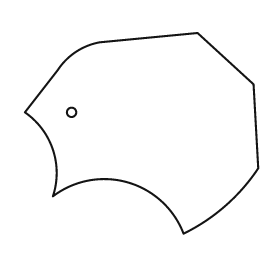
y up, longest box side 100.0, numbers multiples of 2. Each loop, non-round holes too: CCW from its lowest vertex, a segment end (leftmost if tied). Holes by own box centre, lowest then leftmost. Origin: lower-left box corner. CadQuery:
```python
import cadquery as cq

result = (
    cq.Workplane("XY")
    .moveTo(68.0, 0.0)
    .threePointArc((86.0, 12.0), (100.0, 28.0))
    .lineTo(98.0, 64.0)
    .lineTo(74.0, 86.0)
    .lineTo(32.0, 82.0)
    .threePointArc((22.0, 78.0), (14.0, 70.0))
    .lineTo(0.0, 52.0)
    .threePointArc((12.0, 36.0), (12.0, 16.0))
    .threePointArc((44.0, 22.0), (68.0, 0.0))
    .close()
    .moveTo(20.0, 52.0)
    .circle(2.0)
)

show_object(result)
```